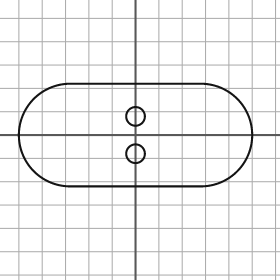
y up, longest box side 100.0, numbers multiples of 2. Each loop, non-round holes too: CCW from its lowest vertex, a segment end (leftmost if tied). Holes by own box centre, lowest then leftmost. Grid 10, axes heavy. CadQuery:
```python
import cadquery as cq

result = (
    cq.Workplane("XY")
    .moveTo(-28.0, -22.0)
    .lineTo(28.0, -22.0)
    .threePointArc((50.0, 0.0), (28.0, 22.0))
    .lineTo(-28.0, 22.0)
    .threePointArc((-50.0, 0.0), (-28.0, -22.0))
    .close()
    .moveTo(0.0, -8.0)
    .circle(4.0)
    .moveTo(0.0, 8.0)
    .circle(4.0)
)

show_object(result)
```